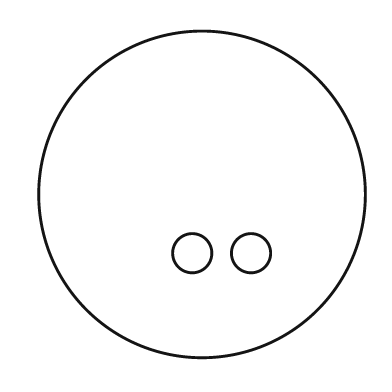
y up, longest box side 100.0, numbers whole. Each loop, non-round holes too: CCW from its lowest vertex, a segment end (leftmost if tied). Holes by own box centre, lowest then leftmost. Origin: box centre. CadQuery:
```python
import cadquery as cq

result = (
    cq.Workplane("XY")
    .moveTo(0.0, 0.0)
    .circle(50.0)
    .moveTo(-3.0, -18.0)
    .circle(6.0)
    .moveTo(15.0, -18.0)
    .circle(6.0)
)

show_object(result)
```